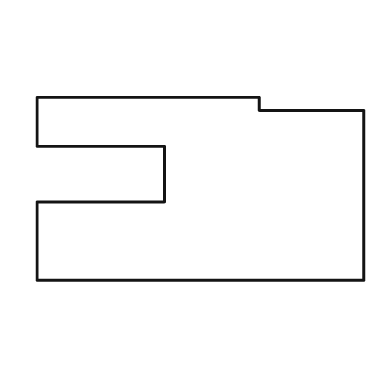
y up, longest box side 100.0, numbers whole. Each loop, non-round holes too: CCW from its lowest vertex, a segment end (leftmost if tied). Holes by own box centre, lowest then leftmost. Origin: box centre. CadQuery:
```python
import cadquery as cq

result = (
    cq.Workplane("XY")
    .moveTo(-50.0, -28.0)
    .lineTo(50.0, -28.0)
    .lineTo(50.0, 24.0)
    .lineTo(18.0, 24.0)
    .lineTo(18.0, 28.0)
    .lineTo(-50.0, 28.0)
    .lineTo(-50.0, 13.0)
    .lineTo(-11.0, 13.0)
    .lineTo(-11.0, -4.0)
    .lineTo(-50.0, -4.0)
    .close()
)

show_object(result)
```